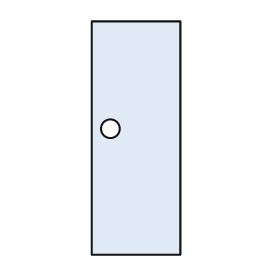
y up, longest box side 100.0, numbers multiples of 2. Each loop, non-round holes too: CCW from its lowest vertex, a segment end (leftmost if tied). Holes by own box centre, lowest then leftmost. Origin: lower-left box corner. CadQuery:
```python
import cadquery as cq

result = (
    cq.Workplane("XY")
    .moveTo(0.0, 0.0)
    .lineTo(38.0, 0.0)
    .lineTo(38.0, 100.0)
    .lineTo(0.0, 100.0)
    .close()
    .moveTo(8.0, 54.0)
    .circle(4.0)
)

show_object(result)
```